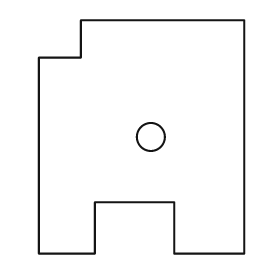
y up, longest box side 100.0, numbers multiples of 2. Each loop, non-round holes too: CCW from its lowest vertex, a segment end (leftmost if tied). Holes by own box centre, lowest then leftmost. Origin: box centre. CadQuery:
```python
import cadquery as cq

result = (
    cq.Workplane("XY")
    .moveTo(-44.0, -50.0)
    .lineTo(-20.0, -50.0)
    .lineTo(-20.0, -28.0)
    .lineTo(14.0, -28.0)
    .lineTo(14.0, -50.0)
    .lineTo(44.0, -50.0)
    .lineTo(44.0, 50.0)
    .lineTo(-26.0, 50.0)
    .lineTo(-26.0, 34.0)
    .lineTo(-44.0, 34.0)
    .close()
    .moveTo(4.0, 0.0)
    .circle(6.0)
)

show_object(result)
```